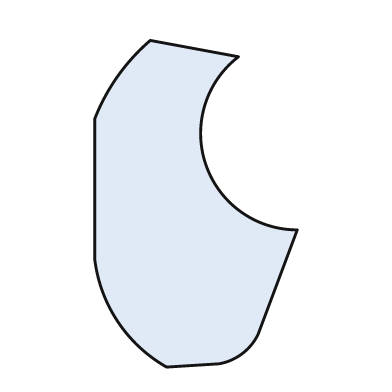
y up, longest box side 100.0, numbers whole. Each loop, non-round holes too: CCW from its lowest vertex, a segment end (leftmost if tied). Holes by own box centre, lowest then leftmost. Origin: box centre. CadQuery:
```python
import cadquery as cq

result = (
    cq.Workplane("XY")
    .moveTo(-9.0, -50.0)
    .lineTo(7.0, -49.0)
    .threePointArc((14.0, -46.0), (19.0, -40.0))
    .lineTo(31.0, -8.0)
    .threePointArc((3.0, 12.0), (13.0, 45.0))
    .lineTo(-14.0, 50.0)
    .threePointArc((-24.0, 39.0), (-31.0, 26.0))
    .lineTo(-31.0, -17.0)
    .threePointArc((-24.0, -36.0), (-9.0, -50.0))
    .close()
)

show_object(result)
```